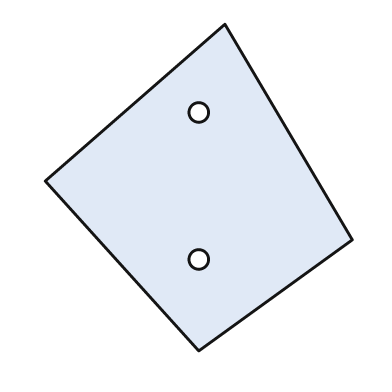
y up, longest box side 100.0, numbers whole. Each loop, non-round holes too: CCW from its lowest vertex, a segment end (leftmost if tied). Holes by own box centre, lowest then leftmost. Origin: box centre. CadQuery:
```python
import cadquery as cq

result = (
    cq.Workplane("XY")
    .moveTo(0.0, -50.0)
    .lineTo(47.0, -16.0)
    .lineTo(8.0, 50.0)
    .lineTo(-47.0, 2.0)
    .close()
    .moveTo(0.0, -22.0)
    .circle(3.0)
    .moveTo(0.0, 23.0)
    .circle(3.0)
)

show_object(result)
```